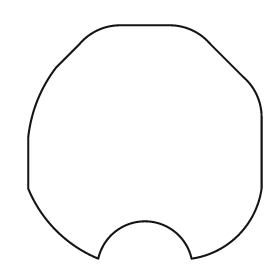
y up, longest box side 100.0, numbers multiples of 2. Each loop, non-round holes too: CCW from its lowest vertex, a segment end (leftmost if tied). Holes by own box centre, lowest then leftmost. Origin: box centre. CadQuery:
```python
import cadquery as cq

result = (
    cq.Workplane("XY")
    .moveTo(-20.0, -50.0)
    .threePointArc((0.0, -34.0), (20.0, -50.0))
    .threePointArc((40.0, -40.0), (50.0, -20.0))
    .lineTo(50.0, 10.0)
    .threePointArc((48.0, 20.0), (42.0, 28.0))
    .lineTo(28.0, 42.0)
    .threePointArc((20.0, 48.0), (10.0, 50.0))
    .lineTo(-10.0, 50.0)
    .threePointArc((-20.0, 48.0), (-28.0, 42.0))
    .lineTo(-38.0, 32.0)
    .threePointArc((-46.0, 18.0), (-50.0, 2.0))
    .lineTo(-50.0, -20.0)
    .threePointArc((-38.0, -38.0), (-20.0, -50.0))
    .close()
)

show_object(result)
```